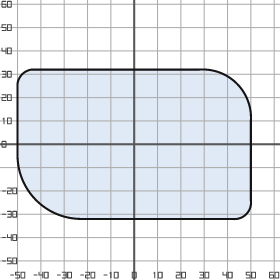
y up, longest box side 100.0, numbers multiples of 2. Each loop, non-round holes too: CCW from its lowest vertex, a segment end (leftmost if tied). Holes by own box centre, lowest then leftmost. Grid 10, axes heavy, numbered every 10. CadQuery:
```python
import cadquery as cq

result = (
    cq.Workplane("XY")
    .moveTo(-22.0, -32.0)
    .lineTo(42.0, -32.0)
    .threePointArc((48.0, -30.0), (50.0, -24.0))
    .lineTo(50.0, 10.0)
    .threePointArc((44.0, 26.0), (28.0, 32.0))
    .lineTo(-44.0, 32.0)
    .threePointArc((-48.0, 30.0), (-50.0, 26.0))
    .lineTo(-50.0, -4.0)
    .threePointArc((-42.0, -24.0), (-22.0, -32.0))
    .close()
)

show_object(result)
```